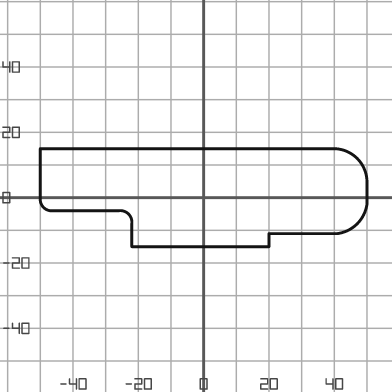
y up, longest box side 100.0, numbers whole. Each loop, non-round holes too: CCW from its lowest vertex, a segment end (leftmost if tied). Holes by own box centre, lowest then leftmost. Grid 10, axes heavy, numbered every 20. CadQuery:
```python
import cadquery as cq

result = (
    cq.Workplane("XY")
    .moveTo(-22.0, -15.0)
    .lineTo(20.0, -15.0)
    .lineTo(20.0, -11.0)
    .lineTo(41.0, -11.0)
    .threePointArc((47.0, -8.0), (50.0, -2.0))
    .lineTo(50.0, 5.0)
    .threePointArc((47.0, 12.0), (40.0, 15.0))
    .lineTo(-50.0, 15.0)
    .lineTo(-50.0, 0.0)
    .threePointArc((-49.0, -3.0), (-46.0, -4.0))
    .lineTo(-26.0, -4.0)
    .threePointArc((-23.0, -5.0), (-22.0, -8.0))
    .close()
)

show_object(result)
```